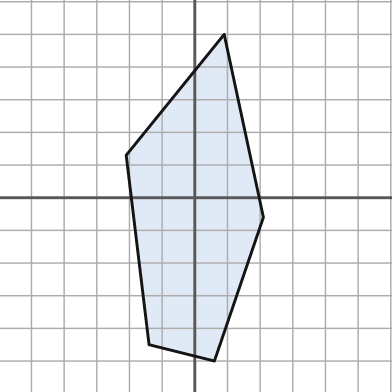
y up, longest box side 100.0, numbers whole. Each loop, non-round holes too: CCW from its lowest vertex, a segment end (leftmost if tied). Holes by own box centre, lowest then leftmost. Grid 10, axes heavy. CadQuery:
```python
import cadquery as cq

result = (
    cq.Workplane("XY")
    .moveTo(6.0, -50.0)
    .lineTo(21.0, -6.0)
    .lineTo(9.0, 50.0)
    .lineTo(-21.0, 13.0)
    .lineTo(-14.0, -45.0)
    .close()
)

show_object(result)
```